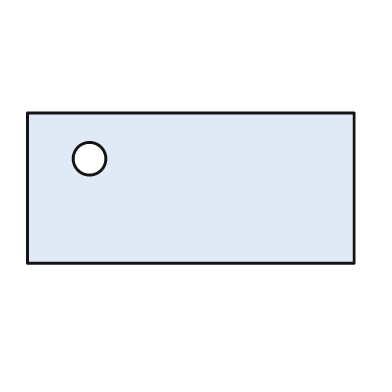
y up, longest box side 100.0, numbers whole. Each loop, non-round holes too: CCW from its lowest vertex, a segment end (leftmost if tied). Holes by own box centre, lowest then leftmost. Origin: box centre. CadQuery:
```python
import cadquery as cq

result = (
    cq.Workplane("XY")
    .moveTo(-50.0, -23.0)
    .lineTo(50.0, -23.0)
    .lineTo(50.0, 23.0)
    .lineTo(-50.0, 23.0)
    .close()
    .moveTo(-31.0, 9.0)
    .circle(5.0)
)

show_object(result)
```